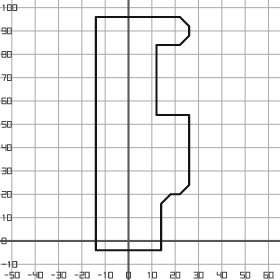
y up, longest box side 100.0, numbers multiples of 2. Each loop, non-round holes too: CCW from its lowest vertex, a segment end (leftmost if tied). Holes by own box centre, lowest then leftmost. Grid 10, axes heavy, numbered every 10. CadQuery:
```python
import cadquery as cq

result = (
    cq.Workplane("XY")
    .moveTo(-14.0, -4.0)
    .lineTo(14.0, -4.0)
    .lineTo(14.0, 16.0)
    .lineTo(18.0, 20.0)
    .lineTo(22.0, 20.0)
    .lineTo(26.0, 24.0)
    .lineTo(26.0, 54.0)
    .lineTo(12.0, 54.0)
    .lineTo(12.0, 84.0)
    .lineTo(22.0, 84.0)
    .lineTo(26.0, 88.0)
    .lineTo(26.0, 92.0)
    .lineTo(22.0, 96.0)
    .lineTo(-14.0, 96.0)
    .close()
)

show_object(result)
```